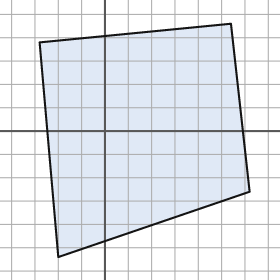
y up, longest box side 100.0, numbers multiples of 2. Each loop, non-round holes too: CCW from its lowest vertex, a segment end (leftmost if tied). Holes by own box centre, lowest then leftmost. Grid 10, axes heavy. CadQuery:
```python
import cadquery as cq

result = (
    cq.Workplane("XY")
    .moveTo(-20.0, -54.0)
    .lineTo(62.0, -26.0)
    .lineTo(54.0, 46.0)
    .lineTo(-28.0, 38.0)
    .close()
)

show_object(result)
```